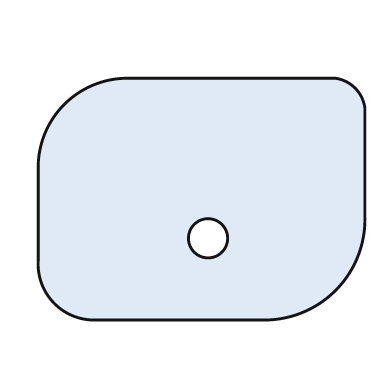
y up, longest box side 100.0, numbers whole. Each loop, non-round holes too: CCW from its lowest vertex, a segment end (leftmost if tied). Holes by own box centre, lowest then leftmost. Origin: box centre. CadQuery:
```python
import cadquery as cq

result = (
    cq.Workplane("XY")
    .moveTo(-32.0, -37.0)
    .lineTo(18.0, -37.0)
    .threePointArc((41.0, -28.0), (50.0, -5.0))
    .lineTo(50.0, 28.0)
    .threePointArc((47.0, 34.0), (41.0, 37.0))
    .lineTo(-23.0, 37.0)
    .threePointArc((-42.0, 29.0), (-50.0, 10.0))
    .lineTo(-50.0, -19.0)
    .threePointArc((-45.0, -32.0), (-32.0, -37.0))
    .close()
    .moveTo(2.0, -12.0)
    .circle(6.0)
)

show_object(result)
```